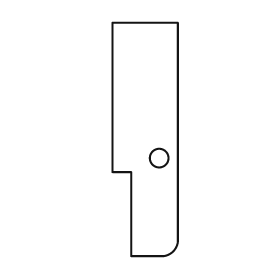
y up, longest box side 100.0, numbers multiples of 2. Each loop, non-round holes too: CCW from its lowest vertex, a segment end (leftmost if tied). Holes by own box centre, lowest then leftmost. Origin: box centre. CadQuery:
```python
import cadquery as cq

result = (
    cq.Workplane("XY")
    .moveTo(-6.0, -50.0)
    .lineTo(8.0, -50.0)
    .threePointArc((12.0, -48.0), (14.0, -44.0))
    .lineTo(14.0, 50.0)
    .lineTo(-14.0, 50.0)
    .lineTo(-14.0, -14.0)
    .lineTo(-6.0, -14.0)
    .close()
    .moveTo(6.0, -8.0)
    .circle(4.0)
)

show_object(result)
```